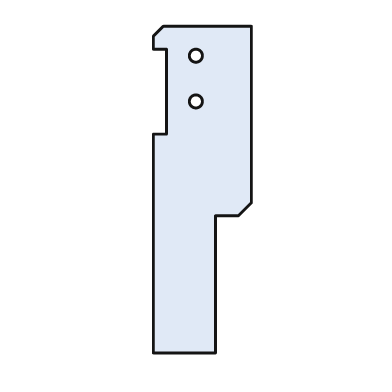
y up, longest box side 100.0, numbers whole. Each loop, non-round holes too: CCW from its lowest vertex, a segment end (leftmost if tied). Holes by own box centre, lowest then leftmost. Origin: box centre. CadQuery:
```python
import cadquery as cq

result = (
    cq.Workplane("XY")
    .moveTo(-15.0, -50.0)
    .lineTo(4.0, -50.0)
    .lineTo(4.0, -8.0)
    .lineTo(11.0, -8.0)
    .lineTo(15.0, -4.0)
    .lineTo(15.0, 50.0)
    .lineTo(-12.0, 50.0)
    .lineTo(-15.0, 47.0)
    .lineTo(-15.0, 43.0)
    .lineTo(-11.0, 43.0)
    .lineTo(-11.0, 17.0)
    .lineTo(-15.0, 17.0)
    .close()
    .moveTo(-2.0, 27.0)
    .circle(2.0)
    .moveTo(-2.0, 41.0)
    .circle(2.0)
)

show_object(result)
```